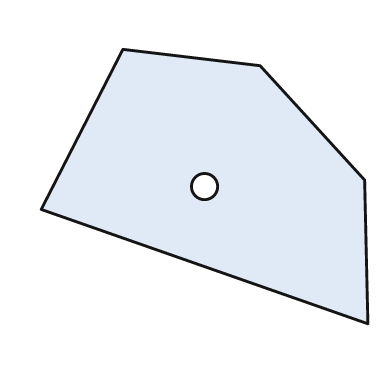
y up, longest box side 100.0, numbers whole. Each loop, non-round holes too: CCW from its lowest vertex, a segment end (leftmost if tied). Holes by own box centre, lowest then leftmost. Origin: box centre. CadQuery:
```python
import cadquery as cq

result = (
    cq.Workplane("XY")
    .moveTo(50.0, -42.0)
    .lineTo(49.0, 2.0)
    .lineTo(17.0, 37.0)
    .lineTo(-25.0, 42.0)
    .lineTo(-50.0, -7.0)
    .close()
    .moveTo(0.0, 0.0)
    .circle(4.0)
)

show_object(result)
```